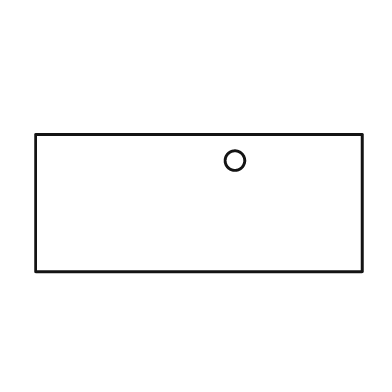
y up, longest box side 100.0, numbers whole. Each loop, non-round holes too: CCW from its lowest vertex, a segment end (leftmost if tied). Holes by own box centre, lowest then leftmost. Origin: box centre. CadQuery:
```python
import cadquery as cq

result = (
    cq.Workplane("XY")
    .moveTo(-50.0, -21.0)
    .lineTo(50.0, -21.0)
    .lineTo(50.0, 21.0)
    .lineTo(-50.0, 21.0)
    .close()
    .moveTo(11.0, 13.0)
    .circle(3.0)
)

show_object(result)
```